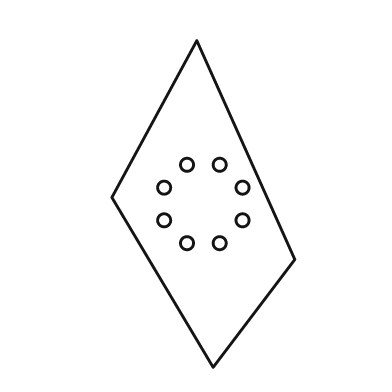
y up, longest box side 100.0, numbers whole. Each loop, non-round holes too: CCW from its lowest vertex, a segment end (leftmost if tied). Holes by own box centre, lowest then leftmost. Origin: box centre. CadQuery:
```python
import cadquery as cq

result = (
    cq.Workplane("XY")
    .moveTo(3.0, -50.0)
    .lineTo(28.0, -17.0)
    .lineTo(-2.0, 50.0)
    .lineTo(-28.0, 2.0)
    .close()
    .moveTo(-5.0, -12.0)
    .circle(2.0)
    .moveTo(5.0, -12.0)
    .circle(2.0)
    .moveTo(-12.0, -5.0)
    .circle(2.0)
    .moveTo(12.0, -5.0)
    .circle(2.0)
    .moveTo(-12.0, 5.0)
    .circle(2.0)
    .moveTo(12.0, 5.0)
    .circle(2.0)
    .moveTo(-5.0, 12.0)
    .circle(2.0)
    .moveTo(5.0, 12.0)
    .circle(2.0)
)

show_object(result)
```